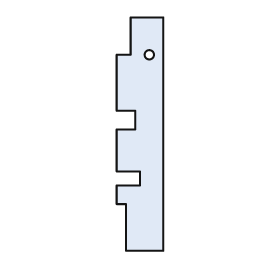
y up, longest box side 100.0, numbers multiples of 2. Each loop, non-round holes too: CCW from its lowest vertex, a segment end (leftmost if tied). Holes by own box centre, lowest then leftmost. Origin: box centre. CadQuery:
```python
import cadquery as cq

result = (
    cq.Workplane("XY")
    .moveTo(-6.0, -50.0)
    .lineTo(10.0, -50.0)
    .lineTo(10.0, 50.0)
    .lineTo(-4.0, 50.0)
    .lineTo(-4.0, 34.0)
    .lineTo(-10.0, 34.0)
    .lineTo(-10.0, 10.0)
    .lineTo(-2.0, 10.0)
    .lineTo(-2.0, 2.0)
    .lineTo(-10.0, 2.0)
    .lineTo(-10.0, -16.0)
    .lineTo(0.0, -16.0)
    .lineTo(0.0, -22.0)
    .lineTo(-10.0, -22.0)
    .lineTo(-10.0, -30.0)
    .lineTo(-6.0, -30.0)
    .close()
    .moveTo(4.0, 34.0)
    .circle(2.0)
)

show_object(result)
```